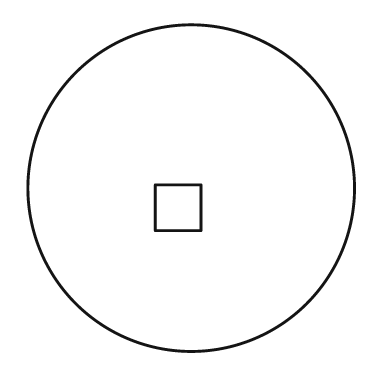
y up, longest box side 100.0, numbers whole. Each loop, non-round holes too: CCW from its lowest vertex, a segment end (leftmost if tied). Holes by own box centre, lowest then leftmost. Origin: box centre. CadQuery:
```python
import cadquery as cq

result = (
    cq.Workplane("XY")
    .moveTo(0.0, 0.0)
    .circle(50.0)
    .moveTo(-11.0, -13.0)
    .lineTo(3.0, -13.0)
    .lineTo(3.0, 1.0)
    .lineTo(-11.0, 1.0)
    .close()
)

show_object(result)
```